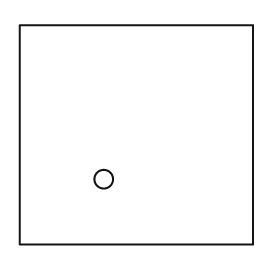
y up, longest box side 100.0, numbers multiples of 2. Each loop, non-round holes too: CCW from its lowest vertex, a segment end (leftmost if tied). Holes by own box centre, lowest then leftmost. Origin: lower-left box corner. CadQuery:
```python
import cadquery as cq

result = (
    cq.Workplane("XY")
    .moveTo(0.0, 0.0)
    .lineTo(100.0, 0.0)
    .lineTo(100.0, 94.0)
    .lineTo(0.0, 94.0)
    .close()
    .moveTo(36.0, 28.0)
    .circle(4.0)
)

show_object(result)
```